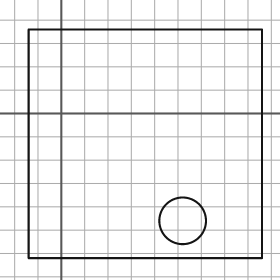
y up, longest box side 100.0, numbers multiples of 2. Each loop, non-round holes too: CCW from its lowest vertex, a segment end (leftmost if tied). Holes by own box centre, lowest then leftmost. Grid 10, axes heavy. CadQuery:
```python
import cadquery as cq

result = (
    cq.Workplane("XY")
    .moveTo(-14.0, -62.0)
    .lineTo(86.0, -62.0)
    .lineTo(86.0, 36.0)
    .lineTo(-14.0, 36.0)
    .close()
    .moveTo(52.0, -46.0)
    .circle(10.0)
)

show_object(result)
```